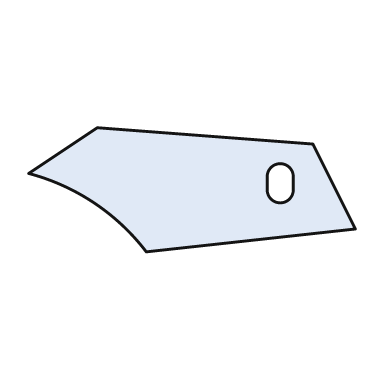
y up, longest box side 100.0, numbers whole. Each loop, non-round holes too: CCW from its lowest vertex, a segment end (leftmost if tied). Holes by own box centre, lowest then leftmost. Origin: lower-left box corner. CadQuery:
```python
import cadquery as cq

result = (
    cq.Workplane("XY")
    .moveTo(36.0, 0.0)
    .lineTo(100.0, 7.0)
    .lineTo(87.0, 33.0)
    .lineTo(21.0, 38.0)
    .lineTo(0.0, 24.0)
    .threePointArc((20.0, 15.0), (36.0, 0.0))
    .close()
    .moveTo(73.0, 19.0)
    .threePointArc((77.0, 15.0), (81.0, 19.0))
    .lineTo(81.0, 23.0)
    .threePointArc((77.0, 27.0), (73.0, 23.0))
    .close()
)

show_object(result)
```